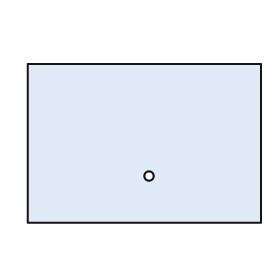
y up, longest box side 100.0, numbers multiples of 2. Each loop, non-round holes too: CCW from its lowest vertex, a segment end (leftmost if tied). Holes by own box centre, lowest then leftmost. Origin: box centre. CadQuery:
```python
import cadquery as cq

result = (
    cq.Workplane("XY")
    .moveTo(-50.0, -34.0)
    .lineTo(50.0, -34.0)
    .lineTo(50.0, 34.0)
    .lineTo(-50.0, 34.0)
    .close()
    .moveTo(2.0, -14.0)
    .circle(2.0)
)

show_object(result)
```